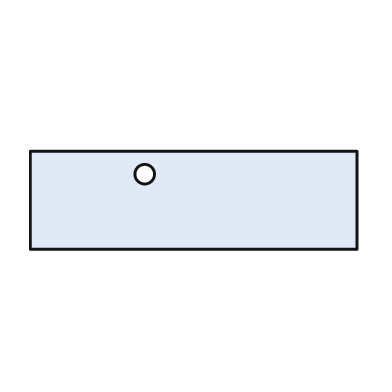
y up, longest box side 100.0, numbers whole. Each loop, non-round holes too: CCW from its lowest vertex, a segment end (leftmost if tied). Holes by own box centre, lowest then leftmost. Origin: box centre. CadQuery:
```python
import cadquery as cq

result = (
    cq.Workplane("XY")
    .moveTo(-50.0, -15.0)
    .lineTo(50.0, -15.0)
    .lineTo(50.0, 15.0)
    .lineTo(-50.0, 15.0)
    .close()
    .moveTo(-15.0, 8.0)
    .circle(3.0)
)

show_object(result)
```